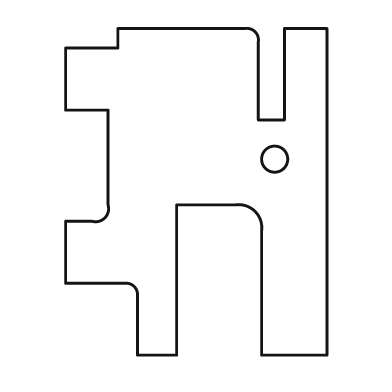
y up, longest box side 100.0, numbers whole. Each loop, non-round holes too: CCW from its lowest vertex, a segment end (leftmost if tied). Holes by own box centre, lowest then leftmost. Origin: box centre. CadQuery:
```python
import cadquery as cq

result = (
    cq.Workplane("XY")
    .moveTo(-18.0, -50.0)
    .lineTo(-6.0, -50.0)
    .lineTo(-6.0, -4.0)
    .lineTo(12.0, -4.0)
    .threePointArc((18.0, -6.0), (20.0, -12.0))
    .lineTo(20.0, -50.0)
    .lineTo(40.0, -50.0)
    .lineTo(40.0, 50.0)
    .lineTo(27.0, 50.0)
    .lineTo(27.0, 22.0)
    .lineTo(19.0, 22.0)
    .lineTo(19.0, 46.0)
    .threePointArc((18.0, 49.0), (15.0, 50.0))
    .lineTo(-24.0, 50.0)
    .lineTo(-24.0, 44.0)
    .lineTo(-40.0, 44.0)
    .lineTo(-40.0, 25.0)
    .lineTo(-27.0, 25.0)
    .lineTo(-27.0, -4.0)
    .threePointArc((-28.0, -8.0), (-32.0, -9.0))
    .lineTo(-40.0, -9.0)
    .lineTo(-40.0, -28.0)
    .lineTo(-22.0, -28.0)
    .threePointArc((-19.0, -29.0), (-18.0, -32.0))
    .close()
    .moveTo(24.0, 10.0)
    .circle(4.0)
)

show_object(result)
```